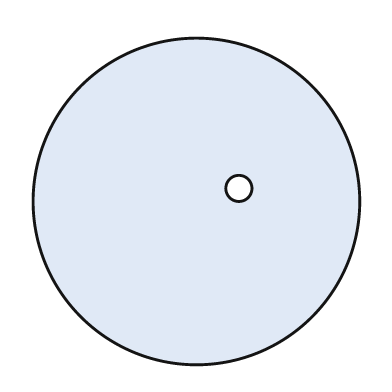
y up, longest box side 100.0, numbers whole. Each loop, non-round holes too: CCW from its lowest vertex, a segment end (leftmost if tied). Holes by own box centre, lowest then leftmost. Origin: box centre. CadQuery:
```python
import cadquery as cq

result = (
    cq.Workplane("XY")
    .moveTo(0.0, 0.0)
    .circle(50.0)
    .moveTo(13.0, 4.0)
    .circle(4.0)
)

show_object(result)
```